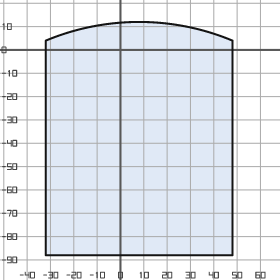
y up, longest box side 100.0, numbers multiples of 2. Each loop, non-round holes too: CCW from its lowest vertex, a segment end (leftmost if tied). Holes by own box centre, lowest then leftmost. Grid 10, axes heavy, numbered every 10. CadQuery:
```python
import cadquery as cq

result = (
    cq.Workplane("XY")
    .moveTo(-32.0, -88.0)
    .lineTo(48.0, -88.0)
    .lineTo(48.0, 4.0)
    .threePointArc((8.0, 12.0), (-32.0, 4.0))
    .close()
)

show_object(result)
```